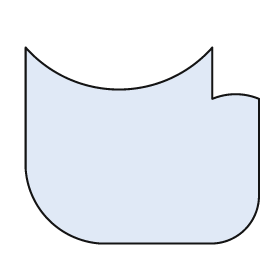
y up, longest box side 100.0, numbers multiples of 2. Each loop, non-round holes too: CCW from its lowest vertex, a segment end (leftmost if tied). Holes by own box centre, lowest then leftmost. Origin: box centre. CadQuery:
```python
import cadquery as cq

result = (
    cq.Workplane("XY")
    .moveTo(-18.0, -42.0)
    .lineTo(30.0, -42.0)
    .threePointArc((44.0, -36.0), (50.0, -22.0))
    .lineTo(50.0, 20.0)
    .threePointArc((40.0, 22.0), (30.0, 20.0))
    .lineTo(30.0, 42.0)
    .threePointArc((-10.0, 24.0), (-50.0, 42.0))
    .lineTo(-50.0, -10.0)
    .threePointArc((-40.0, -32.0), (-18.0, -42.0))
    .close()
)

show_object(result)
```